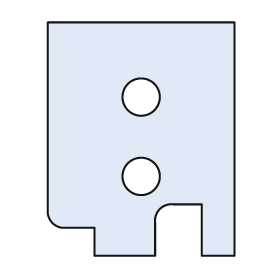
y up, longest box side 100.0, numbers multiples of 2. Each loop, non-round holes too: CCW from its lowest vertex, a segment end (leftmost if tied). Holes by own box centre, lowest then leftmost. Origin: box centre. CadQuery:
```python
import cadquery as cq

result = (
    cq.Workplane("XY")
    .moveTo(-20.0, -50.0)
    .lineTo(6.0, -50.0)
    .lineTo(6.0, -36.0)
    .threePointArc((8.0, -30.0), (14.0, -28.0))
    .lineTo(26.0, -28.0)
    .lineTo(26.0, -50.0)
    .lineTo(40.0, -50.0)
    .lineTo(40.0, 50.0)
    .lineTo(-40.0, 50.0)
    .lineTo(-40.0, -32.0)
    .threePointArc((-38.0, -36.0), (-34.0, -38.0))
    .lineTo(-20.0, -38.0)
    .close()
    .moveTo(0.0, -16.0)
    .circle(8.0)
    .moveTo(0.0, 18.0)
    .circle(8.0)
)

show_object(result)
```